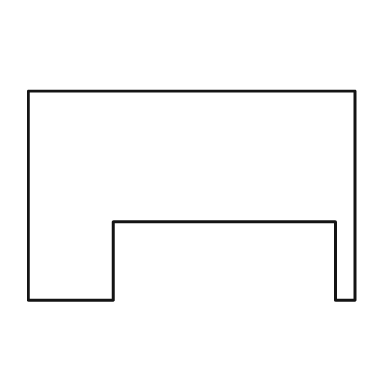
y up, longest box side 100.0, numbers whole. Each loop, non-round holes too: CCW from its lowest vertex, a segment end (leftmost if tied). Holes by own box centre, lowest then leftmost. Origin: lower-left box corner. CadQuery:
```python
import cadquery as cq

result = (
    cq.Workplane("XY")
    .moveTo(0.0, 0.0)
    .lineTo(26.0, 0.0)
    .lineTo(26.0, 24.0)
    .lineTo(94.0, 24.0)
    .lineTo(94.0, 0.0)
    .lineTo(100.0, 0.0)
    .lineTo(100.0, 64.0)
    .lineTo(0.0, 64.0)
    .close()
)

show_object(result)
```